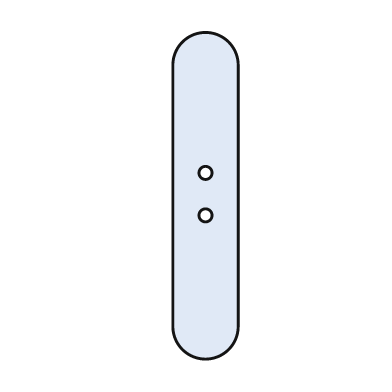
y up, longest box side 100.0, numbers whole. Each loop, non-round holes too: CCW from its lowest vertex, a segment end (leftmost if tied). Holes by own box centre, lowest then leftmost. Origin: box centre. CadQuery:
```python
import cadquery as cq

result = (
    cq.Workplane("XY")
    .moveTo(-10.0, -40.0)
    .threePointArc((0.0, -50.0), (10.0, -40.0))
    .lineTo(10.0, 40.0)
    .threePointArc((0.0, 50.0), (-10.0, 40.0))
    .close()
    .moveTo(0.0, -6.0)
    .circle(2.0)
    .moveTo(0.0, 7.0)
    .circle(2.0)
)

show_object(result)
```